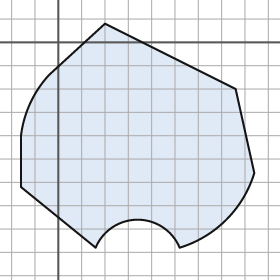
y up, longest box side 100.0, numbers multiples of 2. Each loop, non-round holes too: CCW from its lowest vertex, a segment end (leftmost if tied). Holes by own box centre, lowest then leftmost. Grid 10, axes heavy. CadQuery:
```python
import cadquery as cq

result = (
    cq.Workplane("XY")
    .moveTo(16.0, -88.0)
    .threePointArc((34.0, -76.0), (52.0, -88.0))
    .threePointArc((72.0, -76.0), (84.0, -56.0))
    .lineTo(76.0, -20.0)
    .lineTo(20.0, 8.0)
    .lineTo(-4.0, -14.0)
    .threePointArc((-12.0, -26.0), (-16.0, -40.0))
    .lineTo(-16.0, -62.0)
    .close()
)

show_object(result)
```